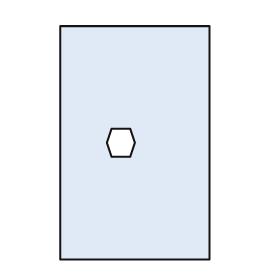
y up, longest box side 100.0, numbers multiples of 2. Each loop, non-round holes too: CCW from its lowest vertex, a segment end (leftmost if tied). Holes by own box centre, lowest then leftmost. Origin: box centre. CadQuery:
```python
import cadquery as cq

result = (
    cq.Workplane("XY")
    .moveTo(-32.0, -50.0)
    .lineTo(32.0, -50.0)
    .lineTo(32.0, 50.0)
    .lineTo(-32.0, 50.0)
    .close()
    .moveTo(-10.0, -6.0)
    .lineTo(-2.0, -6.0)
    .lineTo(0.0, 0.0)
    .lineTo(-2.0, 6.0)
    .lineTo(-10.0, 6.0)
    .lineTo(-12.0, 0.0)
    .close()
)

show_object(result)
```